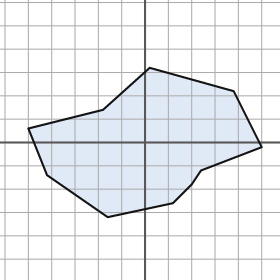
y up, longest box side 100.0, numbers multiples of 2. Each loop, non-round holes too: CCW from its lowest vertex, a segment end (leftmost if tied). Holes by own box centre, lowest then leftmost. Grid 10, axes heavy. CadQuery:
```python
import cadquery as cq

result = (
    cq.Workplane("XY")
    .moveTo(-16.0, -32.0)
    .lineTo(12.0, -26.0)
    .lineTo(20.0, -18.0)
    .lineTo(24.0, -12.0)
    .lineTo(50.0, -2.0)
    .lineTo(38.0, 22.0)
    .lineTo(2.0, 32.0)
    .lineTo(-18.0, 14.0)
    .lineTo(-50.0, 6.0)
    .lineTo(-42.0, -14.0)
    .close()
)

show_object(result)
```